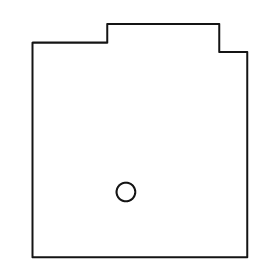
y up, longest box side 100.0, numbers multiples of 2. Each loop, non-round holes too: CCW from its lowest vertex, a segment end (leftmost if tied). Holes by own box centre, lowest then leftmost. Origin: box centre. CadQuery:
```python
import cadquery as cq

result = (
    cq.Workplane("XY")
    .moveTo(-46.0, -50.0)
    .lineTo(46.0, -50.0)
    .lineTo(46.0, 38.0)
    .lineTo(34.0, 38.0)
    .lineTo(34.0, 50.0)
    .lineTo(-14.0, 50.0)
    .lineTo(-14.0, 42.0)
    .lineTo(-46.0, 42.0)
    .close()
    .moveTo(-6.0, -22.0)
    .circle(4.0)
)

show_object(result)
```